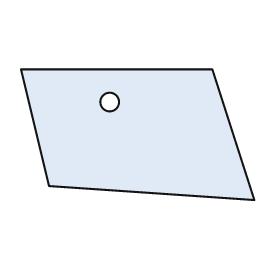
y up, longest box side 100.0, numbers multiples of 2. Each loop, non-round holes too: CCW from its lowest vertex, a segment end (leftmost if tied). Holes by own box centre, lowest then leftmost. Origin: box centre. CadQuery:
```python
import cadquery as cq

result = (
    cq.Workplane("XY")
    .moveTo(50.0, -28.0)
    .lineTo(32.0, 28.0)
    .lineTo(-50.0, 28.0)
    .lineTo(-38.0, -22.0)
    .close()
    .moveTo(-12.0, 14.0)
    .circle(4.0)
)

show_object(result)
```